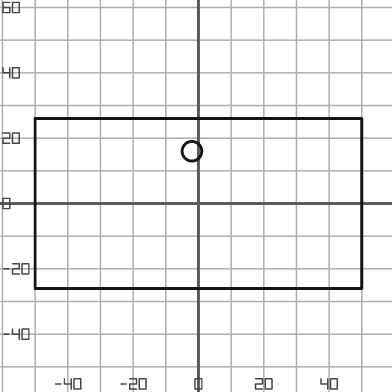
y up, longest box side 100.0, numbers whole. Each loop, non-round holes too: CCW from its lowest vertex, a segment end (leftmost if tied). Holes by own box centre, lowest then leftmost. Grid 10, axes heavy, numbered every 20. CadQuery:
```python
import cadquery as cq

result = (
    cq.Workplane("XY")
    .moveTo(-50.0, -26.0)
    .lineTo(50.0, -26.0)
    .lineTo(50.0, 26.0)
    .lineTo(-50.0, 26.0)
    .close()
    .moveTo(-2.0, 16.0)
    .circle(3.0)
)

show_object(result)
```